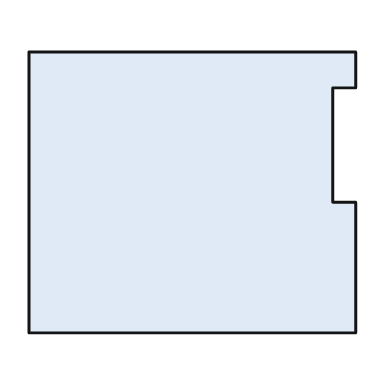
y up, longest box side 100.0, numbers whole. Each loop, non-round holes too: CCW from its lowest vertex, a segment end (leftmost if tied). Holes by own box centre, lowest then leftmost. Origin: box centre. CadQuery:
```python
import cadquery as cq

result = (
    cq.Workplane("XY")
    .moveTo(-50.0, -43.0)
    .lineTo(50.0, -43.0)
    .lineTo(50.0, -3.0)
    .lineTo(43.0, -3.0)
    .lineTo(43.0, 32.0)
    .lineTo(50.0, 32.0)
    .lineTo(50.0, 43.0)
    .lineTo(-50.0, 43.0)
    .close()
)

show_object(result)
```